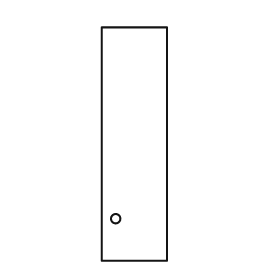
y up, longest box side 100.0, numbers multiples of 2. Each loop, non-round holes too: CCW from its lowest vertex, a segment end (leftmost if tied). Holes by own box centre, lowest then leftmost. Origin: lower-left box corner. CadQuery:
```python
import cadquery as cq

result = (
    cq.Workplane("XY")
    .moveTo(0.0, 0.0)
    .lineTo(28.0, 0.0)
    .lineTo(28.0, 100.0)
    .lineTo(0.0, 100.0)
    .close()
    .moveTo(6.0, 18.0)
    .circle(2.0)
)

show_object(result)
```